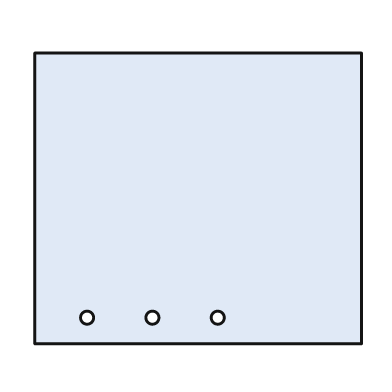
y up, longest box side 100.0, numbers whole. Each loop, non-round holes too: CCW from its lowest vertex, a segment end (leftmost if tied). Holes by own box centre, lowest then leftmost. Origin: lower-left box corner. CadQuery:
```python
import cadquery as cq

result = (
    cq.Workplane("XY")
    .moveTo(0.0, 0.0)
    .lineTo(100.0, 0.0)
    .lineTo(100.0, 89.0)
    .lineTo(0.0, 89.0)
    .close()
    .moveTo(16.0, 8.0)
    .circle(2.0)
    .moveTo(36.0, 8.0)
    .circle(2.0)
    .moveTo(56.0, 8.0)
    .circle(2.0)
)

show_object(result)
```